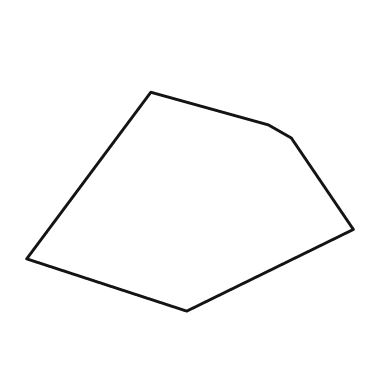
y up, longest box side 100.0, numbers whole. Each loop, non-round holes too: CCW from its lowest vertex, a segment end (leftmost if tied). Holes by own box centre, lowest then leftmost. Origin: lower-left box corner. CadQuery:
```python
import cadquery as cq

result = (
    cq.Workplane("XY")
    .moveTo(49.0, 0.0)
    .lineTo(100.0, 25.0)
    .lineTo(81.0, 53.0)
    .lineTo(74.0, 57.0)
    .lineTo(38.0, 67.0)
    .lineTo(0.0, 16.0)
    .close()
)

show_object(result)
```